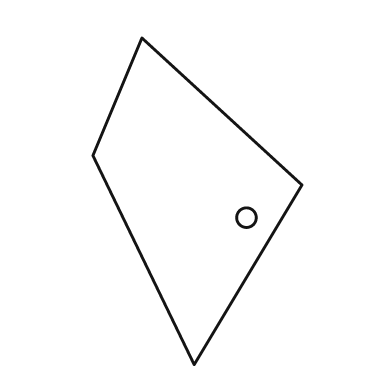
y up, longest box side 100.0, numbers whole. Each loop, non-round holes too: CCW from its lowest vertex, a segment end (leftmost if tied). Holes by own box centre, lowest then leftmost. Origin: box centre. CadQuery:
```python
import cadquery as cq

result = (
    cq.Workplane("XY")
    .moveTo(-1.0, -50.0)
    .lineTo(32.0, 5.0)
    .lineTo(-17.0, 50.0)
    .lineTo(-32.0, 14.0)
    .close()
    .moveTo(15.0, -5.0)
    .circle(3.0)
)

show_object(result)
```